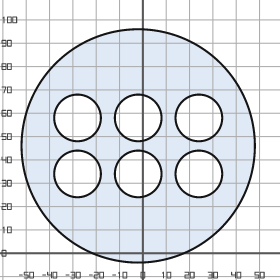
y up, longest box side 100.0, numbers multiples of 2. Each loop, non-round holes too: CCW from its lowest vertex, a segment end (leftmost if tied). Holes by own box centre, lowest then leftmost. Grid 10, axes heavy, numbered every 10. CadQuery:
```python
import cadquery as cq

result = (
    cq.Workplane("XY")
    .moveTo(-2.0, 46.0)
    .circle(50.0)
    .moveTo(-28.0, 34.0)
    .circle(10.0)
    .moveTo(-2.0, 34.0)
    .circle(10.0)
    .moveTo(24.0, 34.0)
    .circle(10.0)
    .moveTo(-28.0, 58.0)
    .circle(10.0)
    .moveTo(-2.0, 58.0)
    .circle(10.0)
    .moveTo(24.0, 58.0)
    .circle(10.0)
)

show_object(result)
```